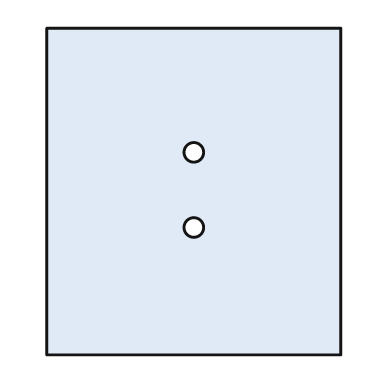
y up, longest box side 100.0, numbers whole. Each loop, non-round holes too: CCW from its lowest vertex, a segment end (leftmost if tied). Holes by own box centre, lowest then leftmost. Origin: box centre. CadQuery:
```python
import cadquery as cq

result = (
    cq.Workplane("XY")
    .moveTo(-45.0, -50.0)
    .lineTo(45.0, -50.0)
    .lineTo(45.0, 50.0)
    .lineTo(-45.0, 50.0)
    .close()
    .moveTo(0.0, -11.0)
    .circle(3.0)
    .moveTo(0.0, 12.0)
    .circle(3.0)
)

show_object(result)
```